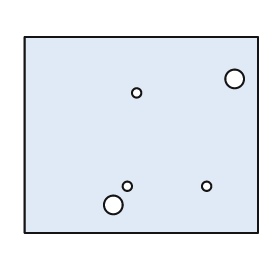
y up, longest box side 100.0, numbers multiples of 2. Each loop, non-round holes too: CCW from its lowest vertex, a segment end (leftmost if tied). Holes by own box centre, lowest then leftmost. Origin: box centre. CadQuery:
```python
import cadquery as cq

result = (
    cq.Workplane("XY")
    .moveTo(-50.0, -42.0)
    .lineTo(50.0, -42.0)
    .lineTo(50.0, 42.0)
    .lineTo(-50.0, 42.0)
    .close()
    .moveTo(-12.0, -30.0)
    .circle(4.0)
    .moveTo(-6.0, -22.0)
    .circle(2.0)
    .moveTo(28.0, -22.0)
    .circle(2.0)
    .moveTo(-2.0, 18.0)
    .circle(2.0)
    .moveTo(40.0, 24.0)
    .circle(4.0)
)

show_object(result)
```